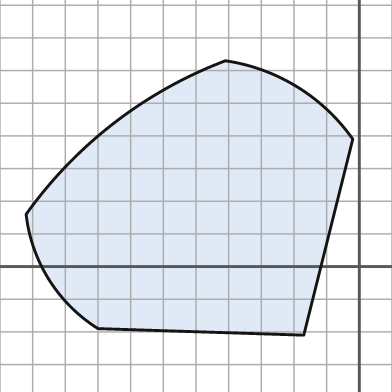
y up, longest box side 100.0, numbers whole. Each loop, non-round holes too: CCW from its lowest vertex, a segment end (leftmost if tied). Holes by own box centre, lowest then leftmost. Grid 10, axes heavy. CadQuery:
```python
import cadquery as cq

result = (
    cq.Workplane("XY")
    .moveTo(-17.0, -21.0)
    .lineTo(-2.0, 39.0)
    .threePointArc((-19.0, 55.0), (-41.0, 63.0))
    .threePointArc((-75.0, 44.0), (-102.0, 16.0))
    .threePointArc((-95.0, -4.0), (-80.0, -19.0))
    .close()
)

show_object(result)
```